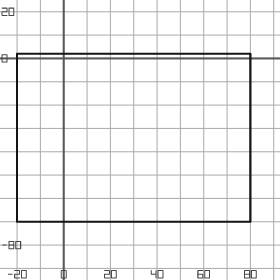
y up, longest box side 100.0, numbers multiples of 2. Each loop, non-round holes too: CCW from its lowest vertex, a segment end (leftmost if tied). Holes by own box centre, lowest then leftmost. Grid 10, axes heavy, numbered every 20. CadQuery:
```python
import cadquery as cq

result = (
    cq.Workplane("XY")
    .moveTo(-20.0, -70.0)
    .lineTo(80.0, -70.0)
    .lineTo(80.0, 2.0)
    .lineTo(-20.0, 2.0)
    .close()
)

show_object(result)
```